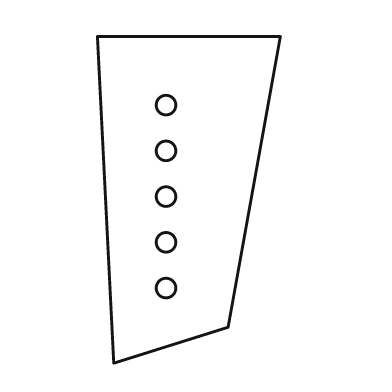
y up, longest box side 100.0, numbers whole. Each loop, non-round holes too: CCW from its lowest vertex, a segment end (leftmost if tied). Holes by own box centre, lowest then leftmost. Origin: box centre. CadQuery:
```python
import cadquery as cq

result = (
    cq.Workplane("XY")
    .moveTo(-23.0, -50.0)
    .lineTo(12.0, -39.0)
    .lineTo(28.0, 50.0)
    .lineTo(-28.0, 50.0)
    .close()
    .moveTo(-7.0, -27.0)
    .circle(3.0)
    .moveTo(-7.0, -13.0)
    .circle(3.0)
    .moveTo(-7.0, 1.0)
    .circle(3.0)
    .moveTo(-7.0, 15.0)
    .circle(3.0)
    .moveTo(-7.0, 29.0)
    .circle(3.0)
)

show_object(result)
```